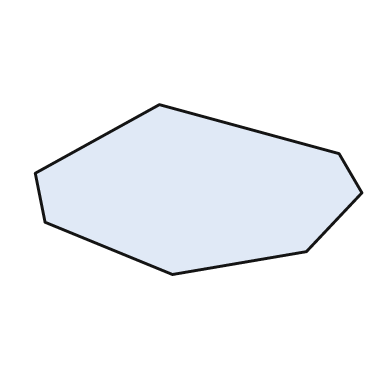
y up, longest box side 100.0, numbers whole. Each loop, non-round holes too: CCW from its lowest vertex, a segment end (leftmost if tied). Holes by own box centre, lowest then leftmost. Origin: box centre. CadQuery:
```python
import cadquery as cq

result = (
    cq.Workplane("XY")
    .moveTo(-8.0, -26.0)
    .lineTo(33.0, -19.0)
    .lineTo(50.0, -1.0)
    .lineTo(43.0, 11.0)
    .lineTo(-12.0, 26.0)
    .lineTo(-50.0, 5.0)
    .lineTo(-47.0, -10.0)
    .close()
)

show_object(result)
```